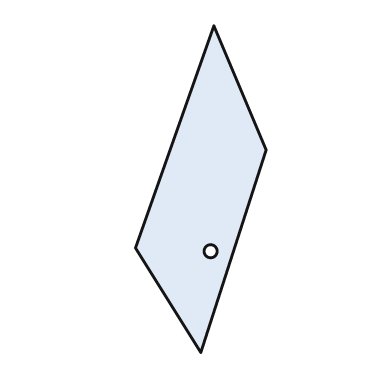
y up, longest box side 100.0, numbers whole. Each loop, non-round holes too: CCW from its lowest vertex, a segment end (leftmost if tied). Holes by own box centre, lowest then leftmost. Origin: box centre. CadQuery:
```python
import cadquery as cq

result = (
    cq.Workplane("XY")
    .moveTo(0.0, -50.0)
    .lineTo(20.0, 12.0)
    .lineTo(4.0, 50.0)
    .lineTo(-20.0, -18.0)
    .close()
    .moveTo(3.0, -19.0)
    .circle(2.0)
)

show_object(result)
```